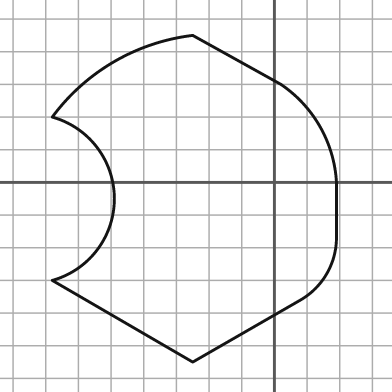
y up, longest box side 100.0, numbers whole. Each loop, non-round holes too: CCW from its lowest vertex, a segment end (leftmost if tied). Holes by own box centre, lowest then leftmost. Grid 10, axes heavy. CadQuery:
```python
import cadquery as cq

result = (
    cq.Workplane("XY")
    .moveTo(-25.0, -55.0)
    .lineTo(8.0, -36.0)
    .threePointArc((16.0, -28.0), (19.0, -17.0))
    .lineTo(19.0, 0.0)
    .threePointArc((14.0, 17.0), (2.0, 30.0))
    .lineTo(-25.0, 45.0)
    .threePointArc((-49.0, 37.0), (-68.0, 20.0))
    .threePointArc((-49.0, -5.0), (-68.0, -30.0))
    .close()
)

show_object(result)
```